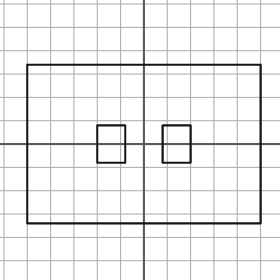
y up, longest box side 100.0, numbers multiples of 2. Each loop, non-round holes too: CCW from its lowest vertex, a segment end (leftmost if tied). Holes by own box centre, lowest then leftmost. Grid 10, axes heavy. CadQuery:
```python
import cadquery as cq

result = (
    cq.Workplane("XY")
    .moveTo(-50.0, -34.0)
    .lineTo(50.0, -34.0)
    .lineTo(50.0, 34.0)
    .lineTo(-50.0, 34.0)
    .close()
    .moveTo(-20.0, -8.0)
    .lineTo(-8.0, -8.0)
    .lineTo(-8.0, 8.0)
    .lineTo(-20.0, 8.0)
    .close()
    .moveTo(8.0, -8.0)
    .lineTo(20.0, -8.0)
    .lineTo(20.0, 8.0)
    .lineTo(8.0, 8.0)
    .close()
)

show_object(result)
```